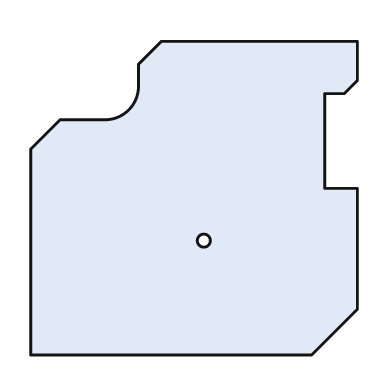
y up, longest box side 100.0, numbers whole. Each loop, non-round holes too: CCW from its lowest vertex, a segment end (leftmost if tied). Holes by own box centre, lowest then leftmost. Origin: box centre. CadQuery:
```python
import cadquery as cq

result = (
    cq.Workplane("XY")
    .moveTo(-50.0, -48.0)
    .lineTo(36.0, -48.0)
    .lineTo(50.0, -34.0)
    .lineTo(50.0, 3.0)
    .lineTo(40.0, 3.0)
    .lineTo(40.0, 32.0)
    .lineTo(46.0, 32.0)
    .lineTo(50.0, 36.0)
    .lineTo(50.0, 48.0)
    .lineTo(-10.0, 48.0)
    .lineTo(-17.0, 41.0)
    .lineTo(-17.0, 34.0)
    .threePointArc((-20.0, 27.0), (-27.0, 24.0))
    .lineTo(-41.0, 24.0)
    .lineTo(-50.0, 15.0)
    .close()
    .moveTo(3.0, -13.0)
    .circle(2.0)
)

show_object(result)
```